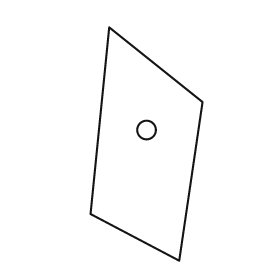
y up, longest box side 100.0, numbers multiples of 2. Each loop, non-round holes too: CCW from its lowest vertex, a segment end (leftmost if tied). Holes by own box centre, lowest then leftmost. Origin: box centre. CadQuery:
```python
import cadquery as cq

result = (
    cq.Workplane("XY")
    .moveTo(14.0, -50.0)
    .lineTo(24.0, 18.0)
    .lineTo(-16.0, 50.0)
    .lineTo(-24.0, -30.0)
    .close()
    .moveTo(0.0, 6.0)
    .circle(4.0)
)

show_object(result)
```